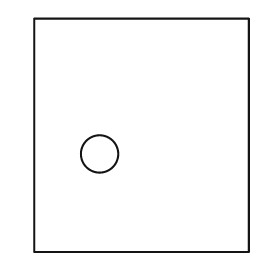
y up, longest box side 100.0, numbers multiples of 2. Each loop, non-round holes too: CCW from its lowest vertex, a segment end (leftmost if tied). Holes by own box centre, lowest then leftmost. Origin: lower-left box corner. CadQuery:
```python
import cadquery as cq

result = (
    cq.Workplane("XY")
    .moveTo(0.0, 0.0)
    .lineTo(92.0, 0.0)
    .lineTo(92.0, 100.0)
    .lineTo(0.0, 100.0)
    .close()
    .moveTo(28.0, 42.0)
    .circle(8.0)
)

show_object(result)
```